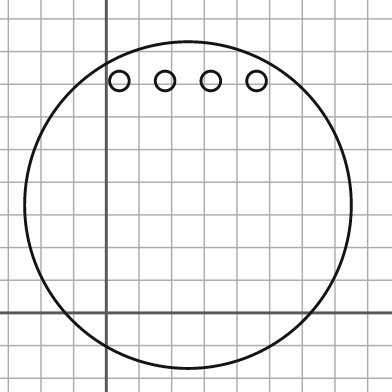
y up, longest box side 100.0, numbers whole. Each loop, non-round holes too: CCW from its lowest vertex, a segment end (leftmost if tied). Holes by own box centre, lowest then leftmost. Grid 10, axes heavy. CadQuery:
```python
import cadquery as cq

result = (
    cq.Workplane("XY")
    .moveTo(25.0, 33.0)
    .circle(50.0)
    .moveTo(4.0, 71.0)
    .circle(3.0)
    .moveTo(18.0, 71.0)
    .circle(3.0)
    .moveTo(32.0, 71.0)
    .circle(3.0)
    .moveTo(46.0, 71.0)
    .circle(3.0)
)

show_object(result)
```